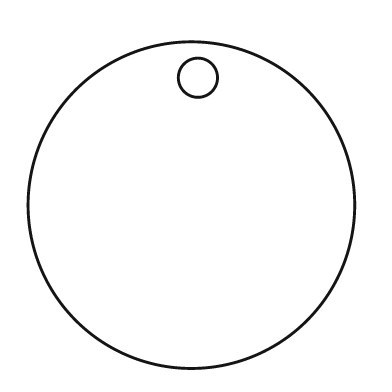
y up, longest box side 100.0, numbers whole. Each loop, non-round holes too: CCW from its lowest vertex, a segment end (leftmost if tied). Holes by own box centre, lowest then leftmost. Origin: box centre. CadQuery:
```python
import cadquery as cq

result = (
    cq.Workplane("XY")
    .moveTo(0.0, 0.0)
    .circle(50.0)
    .moveTo(2.0, 39.0)
    .circle(6.0)
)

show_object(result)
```